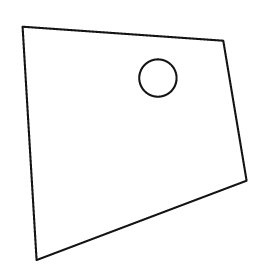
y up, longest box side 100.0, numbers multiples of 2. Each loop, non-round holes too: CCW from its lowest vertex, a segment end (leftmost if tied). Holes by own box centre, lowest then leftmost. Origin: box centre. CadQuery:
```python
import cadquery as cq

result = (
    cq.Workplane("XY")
    .moveTo(-42.0, -50.0)
    .lineTo(48.0, -16.0)
    .lineTo(38.0, 44.0)
    .lineTo(-48.0, 50.0)
    .close()
    .moveTo(10.0, 28.0)
    .circle(8.0)
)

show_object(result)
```